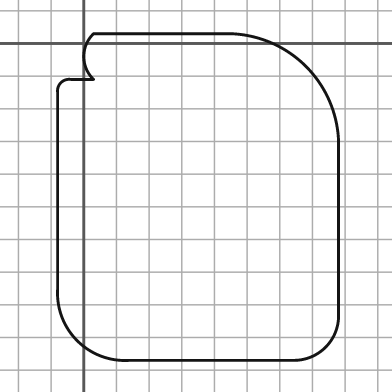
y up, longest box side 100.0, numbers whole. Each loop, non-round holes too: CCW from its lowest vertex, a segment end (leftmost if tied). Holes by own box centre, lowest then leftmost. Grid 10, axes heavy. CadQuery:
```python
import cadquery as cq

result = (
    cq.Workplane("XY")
    .moveTo(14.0, -97.0)
    .lineTo(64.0, -97.0)
    .threePointArc((74.0, -93.0), (78.0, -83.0))
    .lineTo(78.0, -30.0)
    .threePointArc((68.0, -7.0), (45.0, 3.0))
    .lineTo(3.0, 3.0)
    .threePointArc((0.0, -4.0), (3.0, -11.0))
    .lineTo(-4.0, -11.0)
    .threePointArc((-7.0, -12.0), (-8.0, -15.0))
    .lineTo(-8.0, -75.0)
    .threePointArc((-2.0, -91.0), (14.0, -97.0))
    .close()
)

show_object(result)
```